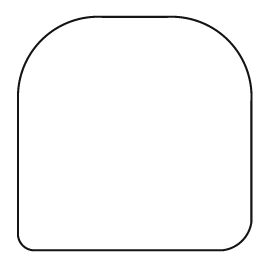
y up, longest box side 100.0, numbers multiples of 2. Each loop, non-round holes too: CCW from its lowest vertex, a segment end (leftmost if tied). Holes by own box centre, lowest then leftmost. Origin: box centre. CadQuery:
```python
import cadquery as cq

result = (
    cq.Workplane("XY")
    .moveTo(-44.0, -50.0)
    .lineTo(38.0, -50.0)
    .threePointArc((46.0, -46.0), (50.0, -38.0))
    .lineTo(50.0, 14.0)
    .threePointArc((40.0, 40.0), (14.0, 50.0))
    .lineTo(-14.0, 50.0)
    .threePointArc((-40.0, 40.0), (-50.0, 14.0))
    .lineTo(-50.0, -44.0)
    .threePointArc((-48.0, -48.0), (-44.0, -50.0))
    .close()
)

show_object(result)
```